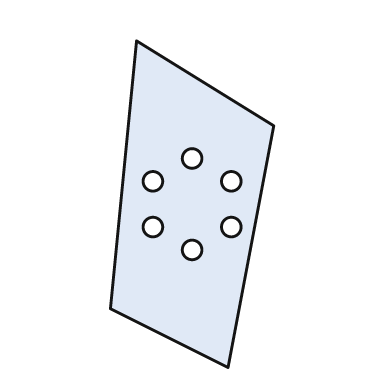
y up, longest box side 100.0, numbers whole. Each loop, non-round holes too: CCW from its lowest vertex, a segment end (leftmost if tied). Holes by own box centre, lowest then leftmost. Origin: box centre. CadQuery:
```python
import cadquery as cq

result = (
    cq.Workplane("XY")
    .moveTo(11.0, -50.0)
    .lineTo(25.0, 24.0)
    .lineTo(-17.0, 50.0)
    .lineTo(-25.0, -32.0)
    .close()
    .moveTo(0.0, -14.0)
    .circle(3.0)
    .moveTo(-12.0, -7.0)
    .circle(3.0)
    .moveTo(12.0, -7.0)
    .circle(3.0)
    .moveTo(-12.0, 7.0)
    .circle(3.0)
    .moveTo(12.0, 7.0)
    .circle(3.0)
    .moveTo(0.0, 14.0)
    .circle(3.0)
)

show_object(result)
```